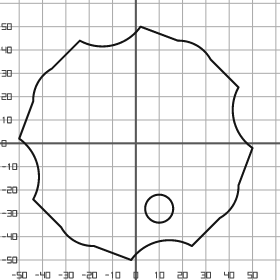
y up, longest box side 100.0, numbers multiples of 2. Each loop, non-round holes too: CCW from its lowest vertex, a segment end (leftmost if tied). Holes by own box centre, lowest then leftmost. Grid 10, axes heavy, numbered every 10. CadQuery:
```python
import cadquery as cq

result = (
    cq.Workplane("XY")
    .moveTo(-2.0, -50.0)
    .threePointArc((10.0, -42.0), (24.0, -44.0))
    .lineTo(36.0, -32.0)
    .threePointArc((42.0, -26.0), (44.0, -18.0))
    .lineTo(50.0, -2.0)
    .threePointArc((42.0, 10.0), (44.0, 24.0))
    .lineTo(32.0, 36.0)
    .threePointArc((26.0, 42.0), (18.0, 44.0))
    .lineTo(2.0, 50.0)
    .threePointArc((-10.0, 42.0), (-24.0, 44.0))
    .lineTo(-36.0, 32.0)
    .threePointArc((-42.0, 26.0), (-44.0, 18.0))
    .lineTo(-50.0, 2.0)
    .threePointArc((-42.0, -10.0), (-44.0, -24.0))
    .lineTo(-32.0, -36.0)
    .threePointArc((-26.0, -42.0), (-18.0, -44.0))
    .close()
    .moveTo(10.0, -28.0)
    .circle(6.0)
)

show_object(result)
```